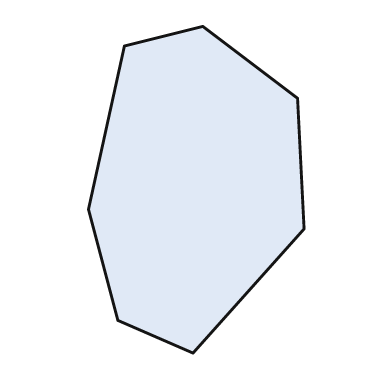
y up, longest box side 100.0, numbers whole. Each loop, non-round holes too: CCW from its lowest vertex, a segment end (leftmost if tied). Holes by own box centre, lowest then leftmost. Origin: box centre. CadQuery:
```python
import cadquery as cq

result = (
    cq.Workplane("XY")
    .moveTo(-1.0, -50.0)
    .lineTo(33.0, -12.0)
    .lineTo(31.0, 28.0)
    .lineTo(2.0, 50.0)
    .lineTo(-22.0, 44.0)
    .lineTo(-33.0, -6.0)
    .lineTo(-24.0, -40.0)
    .close()
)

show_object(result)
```